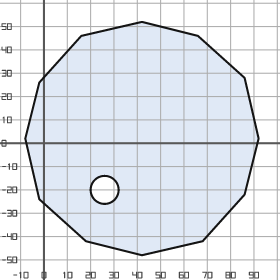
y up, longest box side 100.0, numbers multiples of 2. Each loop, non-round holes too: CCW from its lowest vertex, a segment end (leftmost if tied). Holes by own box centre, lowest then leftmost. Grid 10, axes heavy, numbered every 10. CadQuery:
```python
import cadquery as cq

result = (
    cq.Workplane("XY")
    .moveTo(42.0, -48.0)
    .lineTo(68.0, -42.0)
    .lineTo(86.0, -22.0)
    .lineTo(92.0, 2.0)
    .lineTo(86.0, 28.0)
    .lineTo(66.0, 46.0)
    .lineTo(42.0, 52.0)
    .lineTo(16.0, 46.0)
    .lineTo(-2.0, 26.0)
    .lineTo(-8.0, 2.0)
    .lineTo(-2.0, -24.0)
    .lineTo(18.0, -42.0)
    .close()
    .moveTo(26.0, -20.0)
    .circle(6.0)
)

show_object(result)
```